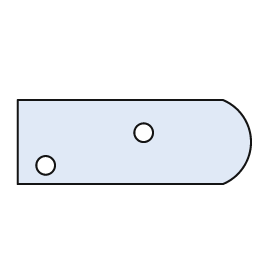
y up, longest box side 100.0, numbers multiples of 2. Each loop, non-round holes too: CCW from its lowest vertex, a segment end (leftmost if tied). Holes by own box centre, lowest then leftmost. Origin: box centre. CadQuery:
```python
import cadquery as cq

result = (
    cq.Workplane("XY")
    .moveTo(-50.0, -18.0)
    .lineTo(38.0, -18.0)
    .threePointArc((50.0, 0.0), (38.0, 18.0))
    .lineTo(-50.0, 18.0)
    .close()
    .moveTo(-38.0, -10.0)
    .circle(4.0)
    .moveTo(4.0, 4.0)
    .circle(4.0)
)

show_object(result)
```